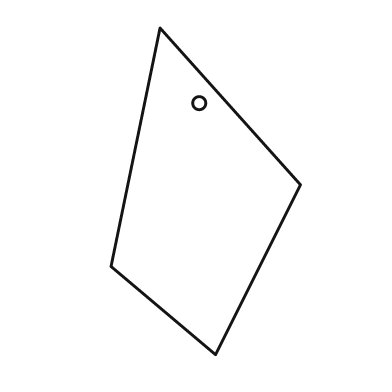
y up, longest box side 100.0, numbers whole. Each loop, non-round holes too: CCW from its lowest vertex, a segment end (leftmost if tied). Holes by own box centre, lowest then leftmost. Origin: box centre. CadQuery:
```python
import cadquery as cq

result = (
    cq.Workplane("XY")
    .moveTo(3.0, -50.0)
    .lineTo(29.0, 2.0)
    .lineTo(-14.0, 50.0)
    .lineTo(-29.0, -23.0)
    .close()
    .moveTo(-2.0, 27.0)
    .circle(2.0)
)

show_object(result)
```